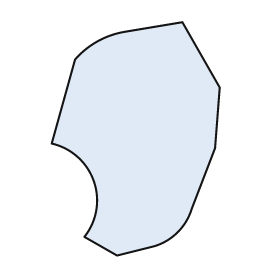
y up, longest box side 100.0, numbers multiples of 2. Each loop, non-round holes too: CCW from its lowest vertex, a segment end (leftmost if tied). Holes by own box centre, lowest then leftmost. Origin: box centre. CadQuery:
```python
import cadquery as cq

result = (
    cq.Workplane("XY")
    .moveTo(-8.0, -50.0)
    .lineTo(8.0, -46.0)
    .threePointArc((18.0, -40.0), (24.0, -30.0))
    .lineTo(34.0, -4.0)
    .lineTo(36.0, 22.0)
    .lineTo(20.0, 50.0)
    .lineTo(-4.0, 46.0)
    .threePointArc((-16.0, 42.0), (-26.0, 34.0))
    .lineTo(-36.0, -2.0)
    .threePointArc((-18.0, -18.0), (-22.0, -42.0))
    .close()
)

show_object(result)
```